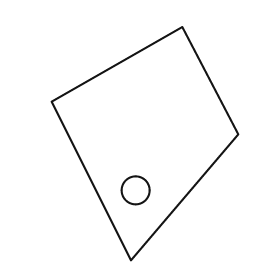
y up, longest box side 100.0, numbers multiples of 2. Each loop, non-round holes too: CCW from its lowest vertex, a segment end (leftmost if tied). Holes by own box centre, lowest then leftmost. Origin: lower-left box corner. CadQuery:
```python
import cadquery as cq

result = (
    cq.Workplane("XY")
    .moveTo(34.0, 0.0)
    .lineTo(80.0, 54.0)
    .lineTo(56.0, 100.0)
    .lineTo(0.0, 68.0)
    .close()
    .moveTo(36.0, 30.0)
    .circle(6.0)
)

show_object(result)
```